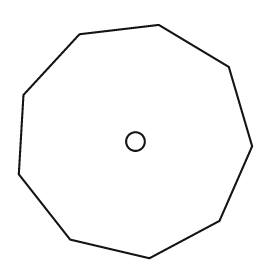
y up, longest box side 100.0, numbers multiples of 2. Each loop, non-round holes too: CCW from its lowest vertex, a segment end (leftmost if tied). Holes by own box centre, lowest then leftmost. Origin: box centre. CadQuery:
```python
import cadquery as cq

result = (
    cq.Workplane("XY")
    .moveTo(6.0, -50.0)
    .lineTo(36.0, -34.0)
    .lineTo(50.0, -2.0)
    .lineTo(40.0, 32.0)
    .lineTo(10.0, 50.0)
    .lineTo(-24.0, 46.0)
    .lineTo(-48.0, 20.0)
    .lineTo(-50.0, -14.0)
    .lineTo(-28.0, -42.0)
    .close()
    .moveTo(0.0, 0.0)
    .circle(4.0)
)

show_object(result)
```